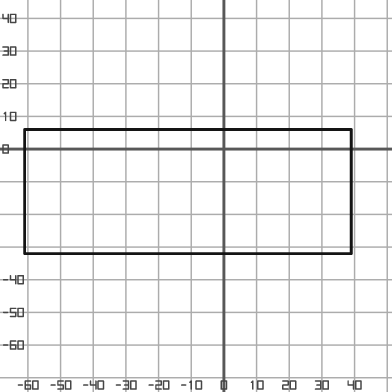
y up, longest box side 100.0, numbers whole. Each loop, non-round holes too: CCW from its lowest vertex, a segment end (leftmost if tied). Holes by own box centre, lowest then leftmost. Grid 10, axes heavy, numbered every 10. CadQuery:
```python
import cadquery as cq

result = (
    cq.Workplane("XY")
    .moveTo(-61.0, -32.0)
    .lineTo(39.0, -32.0)
    .lineTo(39.0, 6.0)
    .lineTo(-61.0, 6.0)
    .close()
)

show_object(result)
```